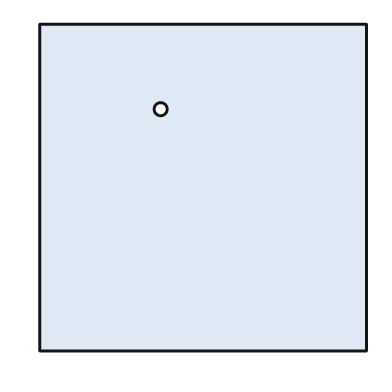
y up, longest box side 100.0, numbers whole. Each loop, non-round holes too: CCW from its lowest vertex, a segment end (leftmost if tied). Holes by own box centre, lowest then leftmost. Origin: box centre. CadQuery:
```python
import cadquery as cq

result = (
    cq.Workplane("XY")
    .moveTo(-50.0, -50.0)
    .lineTo(50.0, -50.0)
    .lineTo(50.0, 50.0)
    .lineTo(-50.0, 50.0)
    .close()
    .moveTo(-13.0, 24.0)
    .circle(2.0)
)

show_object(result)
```